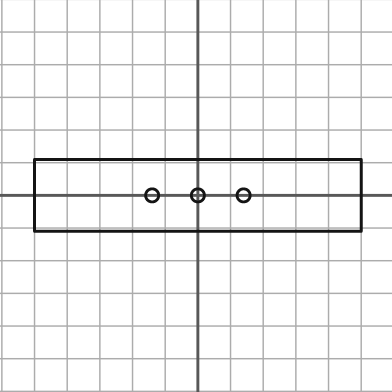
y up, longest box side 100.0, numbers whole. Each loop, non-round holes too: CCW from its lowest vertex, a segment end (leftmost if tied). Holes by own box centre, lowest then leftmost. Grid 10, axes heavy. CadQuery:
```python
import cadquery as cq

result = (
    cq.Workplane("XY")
    .moveTo(-50.0, -11.0)
    .lineTo(50.0, -11.0)
    .lineTo(50.0, 11.0)
    .lineTo(-50.0, 11.0)
    .close()
    .moveTo(-14.0, 0.0)
    .circle(2.0)
    .moveTo(0.0, 0.0)
    .circle(2.0)
    .moveTo(14.0, 0.0)
    .circle(2.0)
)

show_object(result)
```